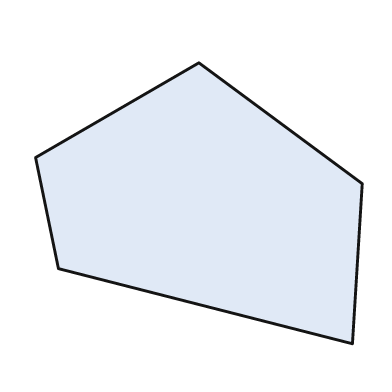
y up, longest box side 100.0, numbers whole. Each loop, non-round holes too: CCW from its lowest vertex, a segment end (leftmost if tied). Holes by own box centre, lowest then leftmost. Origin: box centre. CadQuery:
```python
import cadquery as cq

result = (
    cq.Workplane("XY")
    .moveTo(47.0, -43.0)
    .lineTo(50.0, 6.0)
    .lineTo(0.0, 43.0)
    .lineTo(-50.0, 14.0)
    .lineTo(-43.0, -20.0)
    .close()
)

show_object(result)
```